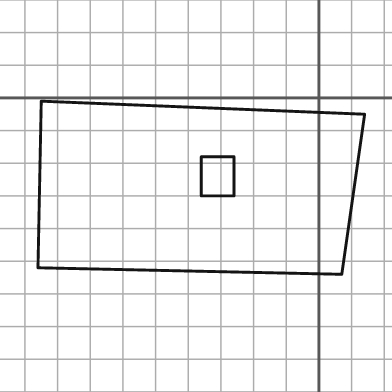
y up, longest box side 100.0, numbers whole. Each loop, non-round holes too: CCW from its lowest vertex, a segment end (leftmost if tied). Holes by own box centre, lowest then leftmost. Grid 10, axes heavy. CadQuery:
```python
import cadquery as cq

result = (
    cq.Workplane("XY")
    .moveTo(7.0, -54.0)
    .lineTo(14.0, -5.0)
    .lineTo(-85.0, -1.0)
    .lineTo(-86.0, -52.0)
    .close()
    .moveTo(-36.0, -30.0)
    .lineTo(-26.0, -30.0)
    .lineTo(-26.0, -18.0)
    .lineTo(-36.0, -18.0)
    .close()
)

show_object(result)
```